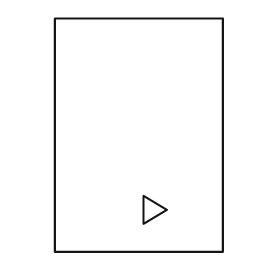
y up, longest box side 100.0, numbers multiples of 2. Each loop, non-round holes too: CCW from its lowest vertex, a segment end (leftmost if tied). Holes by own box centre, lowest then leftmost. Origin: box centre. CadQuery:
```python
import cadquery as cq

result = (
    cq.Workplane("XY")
    .moveTo(-36.0, -50.0)
    .lineTo(36.0, -50.0)
    .lineTo(36.0, 50.0)
    .lineTo(-36.0, 50.0)
    .close()
    .moveTo(2.0, -38.0)
    .lineTo(12.0, -32.0)
    .lineTo(2.0, -26.0)
    .close()
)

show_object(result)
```